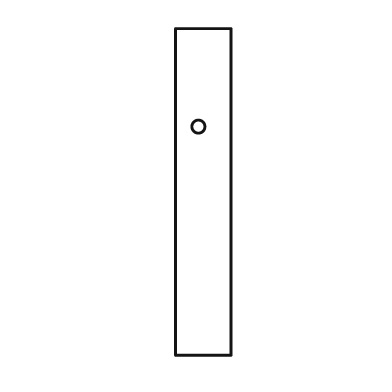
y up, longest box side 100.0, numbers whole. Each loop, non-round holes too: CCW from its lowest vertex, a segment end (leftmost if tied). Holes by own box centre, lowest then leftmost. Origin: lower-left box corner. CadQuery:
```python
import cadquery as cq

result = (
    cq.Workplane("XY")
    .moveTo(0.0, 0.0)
    .lineTo(17.0, 0.0)
    .lineTo(17.0, 100.0)
    .lineTo(0.0, 100.0)
    .close()
    .moveTo(7.0, 70.0)
    .circle(2.0)
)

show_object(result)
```